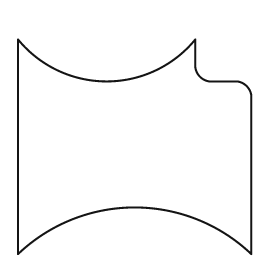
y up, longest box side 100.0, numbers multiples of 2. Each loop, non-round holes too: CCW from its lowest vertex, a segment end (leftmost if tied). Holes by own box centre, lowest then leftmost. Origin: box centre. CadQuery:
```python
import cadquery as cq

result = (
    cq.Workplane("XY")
    .moveTo(-50.0, -46.0)
    .threePointArc((0.0, -26.0), (50.0, -46.0))
    .lineTo(50.0, 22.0)
    .threePointArc((48.0, 26.0), (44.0, 28.0))
    .lineTo(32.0, 28.0)
    .threePointArc((28.0, 30.0), (26.0, 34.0))
    .lineTo(26.0, 46.0)
    .threePointArc((-12.0, 28.0), (-50.0, 46.0))
    .close()
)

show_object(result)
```